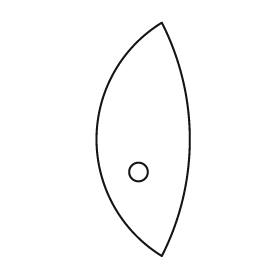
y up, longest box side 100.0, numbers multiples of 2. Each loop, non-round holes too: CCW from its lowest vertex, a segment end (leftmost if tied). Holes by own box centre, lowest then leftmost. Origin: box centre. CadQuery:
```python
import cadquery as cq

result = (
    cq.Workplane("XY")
    .moveTo(8.0, -50.0)
    .threePointArc((20.0, 0.0), (8.0, 50.0))
    .threePointArc((-20.0, 0.0), (8.0, -50.0))
    .close()
    .moveTo(-2.0, -14.0)
    .circle(4.0)
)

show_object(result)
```